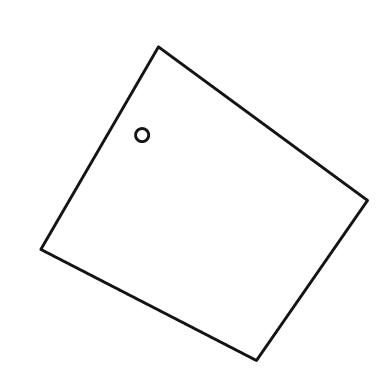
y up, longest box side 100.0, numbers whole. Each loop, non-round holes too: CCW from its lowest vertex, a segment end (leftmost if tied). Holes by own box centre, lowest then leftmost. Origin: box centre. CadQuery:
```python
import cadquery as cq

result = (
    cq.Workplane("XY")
    .moveTo(16.0, -48.0)
    .lineTo(50.0, 1.0)
    .lineTo(-14.0, 48.0)
    .lineTo(-50.0, -14.0)
    .close()
    .moveTo(-19.0, 21.0)
    .circle(2.0)
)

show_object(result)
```